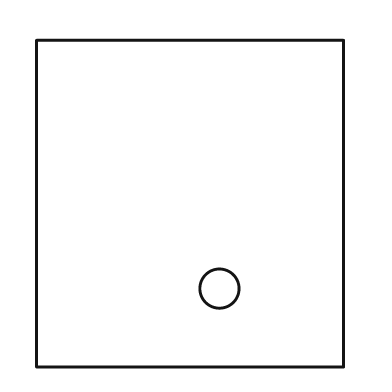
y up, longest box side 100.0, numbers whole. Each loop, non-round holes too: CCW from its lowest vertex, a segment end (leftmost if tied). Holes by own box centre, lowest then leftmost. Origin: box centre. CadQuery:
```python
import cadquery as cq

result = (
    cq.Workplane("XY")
    .moveTo(-47.0, -50.0)
    .lineTo(47.0, -50.0)
    .lineTo(47.0, 50.0)
    .lineTo(-47.0, 50.0)
    .close()
    .moveTo(9.0, -26.0)
    .circle(6.0)
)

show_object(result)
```